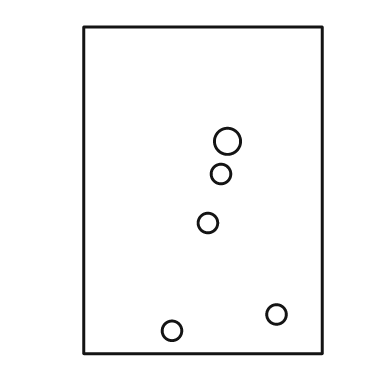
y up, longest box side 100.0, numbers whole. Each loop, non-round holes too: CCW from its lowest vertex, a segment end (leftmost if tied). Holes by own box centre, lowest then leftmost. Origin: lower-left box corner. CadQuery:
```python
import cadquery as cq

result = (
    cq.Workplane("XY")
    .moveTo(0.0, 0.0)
    .lineTo(73.0, 0.0)
    .lineTo(73.0, 100.0)
    .lineTo(0.0, 100.0)
    .close()
    .moveTo(27.0, 7.0)
    .circle(3.0)
    .moveTo(59.0, 12.0)
    .circle(3.0)
    .moveTo(38.0, 40.0)
    .circle(3.0)
    .moveTo(42.0, 55.0)
    .circle(3.0)
    .moveTo(44.0, 65.0)
    .circle(4.0)
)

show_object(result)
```